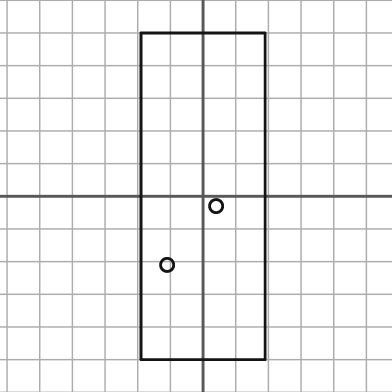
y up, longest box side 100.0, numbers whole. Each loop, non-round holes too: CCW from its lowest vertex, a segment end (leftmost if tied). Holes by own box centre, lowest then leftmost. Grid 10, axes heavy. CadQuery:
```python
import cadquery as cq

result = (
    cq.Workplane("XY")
    .moveTo(-19.0, -50.0)
    .lineTo(19.0, -50.0)
    .lineTo(19.0, 50.0)
    .lineTo(-19.0, 50.0)
    .close()
    .moveTo(-11.0, -21.0)
    .circle(2.0)
    .moveTo(4.0, -3.0)
    .circle(2.0)
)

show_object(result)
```